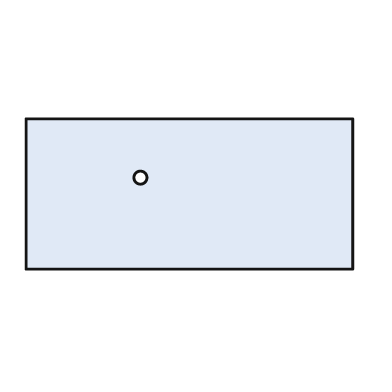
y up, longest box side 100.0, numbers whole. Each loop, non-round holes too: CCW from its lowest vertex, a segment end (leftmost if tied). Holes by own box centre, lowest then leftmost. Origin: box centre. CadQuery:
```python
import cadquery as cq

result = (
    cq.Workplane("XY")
    .moveTo(-50.0, -23.0)
    .lineTo(50.0, -23.0)
    .lineTo(50.0, 23.0)
    .lineTo(-50.0, 23.0)
    .close()
    .moveTo(-15.0, 5.0)
    .circle(2.0)
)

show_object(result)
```